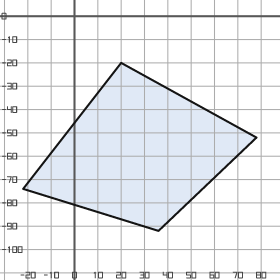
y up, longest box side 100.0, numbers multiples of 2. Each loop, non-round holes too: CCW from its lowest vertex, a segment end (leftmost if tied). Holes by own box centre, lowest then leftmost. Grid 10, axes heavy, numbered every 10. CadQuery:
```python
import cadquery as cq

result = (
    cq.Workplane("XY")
    .moveTo(36.0, -92.0)
    .lineTo(78.0, -52.0)
    .lineTo(20.0, -20.0)
    .lineTo(-22.0, -74.0)
    .close()
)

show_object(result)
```